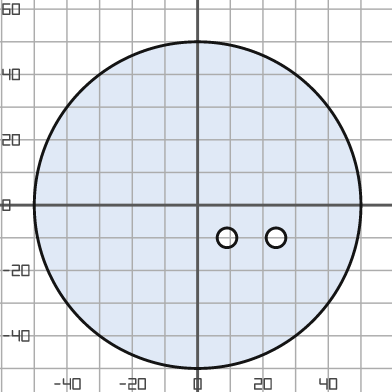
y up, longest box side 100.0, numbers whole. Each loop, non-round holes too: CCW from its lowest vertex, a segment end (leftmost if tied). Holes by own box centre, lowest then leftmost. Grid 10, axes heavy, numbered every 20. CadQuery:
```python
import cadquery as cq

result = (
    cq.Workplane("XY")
    .moveTo(0.0, 0.0)
    .circle(50.0)
    .moveTo(9.0, -10.0)
    .circle(3.0)
    .moveTo(24.0, -10.0)
    .circle(3.0)
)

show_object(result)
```